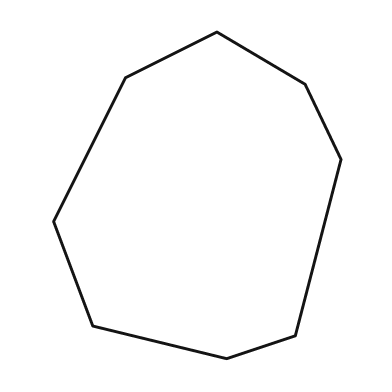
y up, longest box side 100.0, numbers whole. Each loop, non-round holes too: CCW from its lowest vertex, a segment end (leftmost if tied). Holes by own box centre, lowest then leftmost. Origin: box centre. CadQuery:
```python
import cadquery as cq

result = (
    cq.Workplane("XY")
    .moveTo(9.0, -50.0)
    .lineTo(30.0, -43.0)
    .lineTo(44.0, 11.0)
    .lineTo(33.0, 34.0)
    .lineTo(6.0, 50.0)
    .lineTo(-22.0, 36.0)
    .lineTo(-44.0, -8.0)
    .lineTo(-32.0, -40.0)
    .close()
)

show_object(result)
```